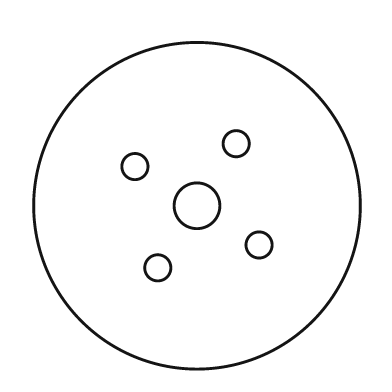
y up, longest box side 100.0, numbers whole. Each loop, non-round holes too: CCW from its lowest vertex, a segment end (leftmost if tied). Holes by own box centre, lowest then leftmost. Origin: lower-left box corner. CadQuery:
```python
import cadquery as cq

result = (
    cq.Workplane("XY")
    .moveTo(50.0, 50.0)
    .circle(50.0)
    .moveTo(38.0, 31.0)
    .circle(4.0)
    .moveTo(69.0, 38.0)
    .circle(4.0)
    .moveTo(50.0, 50.0)
    .circle(7.0)
    .moveTo(31.0, 62.0)
    .circle(4.0)
    .moveTo(62.0, 69.0)
    .circle(4.0)
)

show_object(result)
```